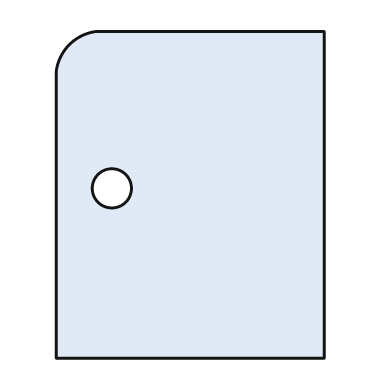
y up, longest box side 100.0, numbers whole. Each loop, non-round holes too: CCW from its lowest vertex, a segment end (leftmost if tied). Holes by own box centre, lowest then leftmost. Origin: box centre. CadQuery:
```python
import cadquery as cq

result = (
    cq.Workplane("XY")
    .moveTo(-41.0, -50.0)
    .lineTo(41.0, -50.0)
    .lineTo(41.0, 50.0)
    .lineTo(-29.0, 50.0)
    .threePointArc((-37.0, 46.0), (-41.0, 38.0))
    .close()
    .moveTo(-24.0, 2.0)
    .circle(6.0)
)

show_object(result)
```